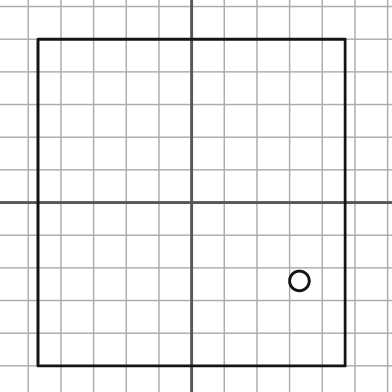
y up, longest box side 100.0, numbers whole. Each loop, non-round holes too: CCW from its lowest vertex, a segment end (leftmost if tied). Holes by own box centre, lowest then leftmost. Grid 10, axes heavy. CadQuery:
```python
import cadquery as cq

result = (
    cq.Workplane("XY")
    .moveTo(-47.0, -50.0)
    .lineTo(47.0, -50.0)
    .lineTo(47.0, 50.0)
    .lineTo(-47.0, 50.0)
    .close()
    .moveTo(33.0, -24.0)
    .circle(3.0)
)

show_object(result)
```